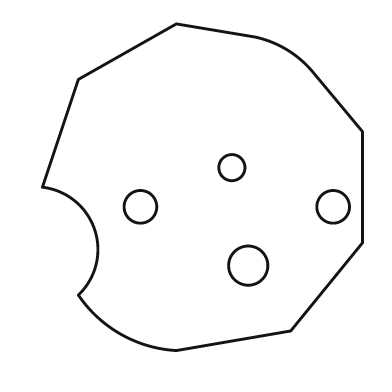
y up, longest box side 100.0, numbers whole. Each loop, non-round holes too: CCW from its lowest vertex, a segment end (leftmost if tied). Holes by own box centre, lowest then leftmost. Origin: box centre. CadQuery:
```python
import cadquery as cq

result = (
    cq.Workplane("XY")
    .moveTo(-8.0, -50.0)
    .lineTo(27.0, -44.0)
    .lineTo(49.0, -17.0)
    .lineTo(49.0, 17.0)
    .lineTo(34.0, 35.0)
    .threePointArc((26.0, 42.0), (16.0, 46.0))
    .lineTo(-8.0, 50.0)
    .lineTo(-38.0, 33.0)
    .lineTo(-49.0, 0.0)
    .threePointArc((-33.0, -13.0), (-38.0, -33.0))
    .threePointArc((-25.0, -45.0), (-8.0, -50.0))
    .close()
    .moveTo(14.0, -24.0)
    .circle(6.0)
    .moveTo(-19.0, -6.0)
    .circle(5.0)
    .moveTo(40.0, -6.0)
    .circle(5.0)
    .moveTo(9.0, 6.0)
    .circle(4.0)
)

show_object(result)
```